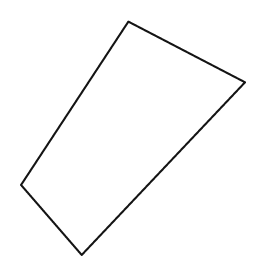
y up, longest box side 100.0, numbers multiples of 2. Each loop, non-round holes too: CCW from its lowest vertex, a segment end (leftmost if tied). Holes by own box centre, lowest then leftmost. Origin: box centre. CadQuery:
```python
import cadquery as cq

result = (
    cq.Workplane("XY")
    .moveTo(-22.0, -50.0)
    .lineTo(48.0, 24.0)
    .lineTo(-2.0, 50.0)
    .lineTo(-48.0, -20.0)
    .close()
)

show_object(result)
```